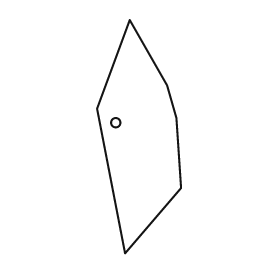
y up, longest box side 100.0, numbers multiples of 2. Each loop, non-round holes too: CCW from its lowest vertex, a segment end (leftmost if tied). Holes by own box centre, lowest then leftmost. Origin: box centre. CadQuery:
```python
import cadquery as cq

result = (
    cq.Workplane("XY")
    .moveTo(-6.0, -50.0)
    .lineTo(18.0, -22.0)
    .lineTo(16.0, 8.0)
    .lineTo(12.0, 22.0)
    .lineTo(-4.0, 50.0)
    .lineTo(-18.0, 12.0)
    .close()
    .moveTo(-10.0, 6.0)
    .circle(2.0)
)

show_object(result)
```